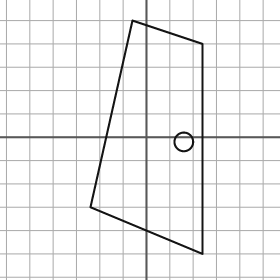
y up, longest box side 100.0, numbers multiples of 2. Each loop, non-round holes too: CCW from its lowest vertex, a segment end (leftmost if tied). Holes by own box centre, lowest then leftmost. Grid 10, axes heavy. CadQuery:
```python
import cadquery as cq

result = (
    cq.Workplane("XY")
    .moveTo(24.0, -50.0)
    .lineTo(24.0, 40.0)
    .lineTo(-6.0, 50.0)
    .lineTo(-24.0, -30.0)
    .close()
    .moveTo(16.0, -2.0)
    .circle(4.0)
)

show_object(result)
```